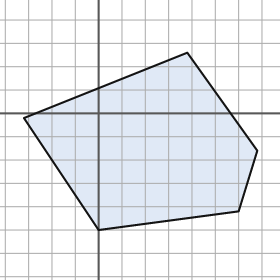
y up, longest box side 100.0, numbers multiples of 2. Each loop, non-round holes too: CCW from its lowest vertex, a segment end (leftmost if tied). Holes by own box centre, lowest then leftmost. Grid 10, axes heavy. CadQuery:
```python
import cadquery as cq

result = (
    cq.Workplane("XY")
    .moveTo(0.0, -50.0)
    .lineTo(60.0, -42.0)
    .lineTo(68.0, -16.0)
    .lineTo(38.0, 26.0)
    .lineTo(-32.0, -2.0)
    .close()
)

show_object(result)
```